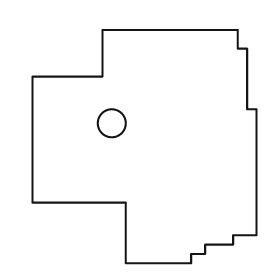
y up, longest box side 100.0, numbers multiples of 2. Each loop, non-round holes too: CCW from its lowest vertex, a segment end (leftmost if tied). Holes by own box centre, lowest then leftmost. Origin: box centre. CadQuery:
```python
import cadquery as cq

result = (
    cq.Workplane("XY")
    .moveTo(-8.0, -50.0)
    .lineTo(20.0, -50.0)
    .lineTo(20.0, -46.0)
    .lineTo(26.0, -46.0)
    .lineTo(26.0, -42.0)
    .lineTo(38.0, -42.0)
    .lineTo(38.0, -38.0)
    .lineTo(48.0, -38.0)
    .lineTo(48.0, 16.0)
    .lineTo(44.0, 16.0)
    .lineTo(44.0, 42.0)
    .lineTo(40.0, 42.0)
    .lineTo(40.0, 50.0)
    .lineTo(-18.0, 50.0)
    .lineTo(-18.0, 30.0)
    .lineTo(-48.0, 30.0)
    .lineTo(-48.0, -24.0)
    .lineTo(-8.0, -24.0)
    .close()
    .moveTo(-14.0, 10.0)
    .circle(6.0)
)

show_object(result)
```